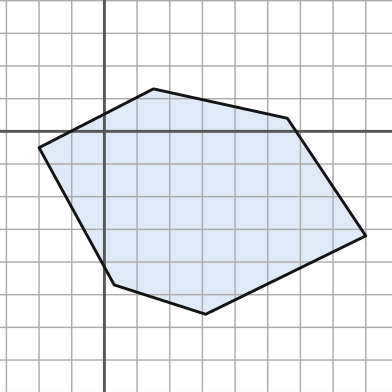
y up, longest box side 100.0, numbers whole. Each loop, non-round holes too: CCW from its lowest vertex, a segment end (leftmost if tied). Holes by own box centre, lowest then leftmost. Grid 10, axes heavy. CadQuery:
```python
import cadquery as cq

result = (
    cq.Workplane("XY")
    .moveTo(31.0, -56.0)
    .lineTo(80.0, -32.0)
    .lineTo(56.0, 4.0)
    .lineTo(15.0, 13.0)
    .lineTo(-20.0, -5.0)
    .lineTo(3.0, -47.0)
    .close()
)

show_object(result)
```